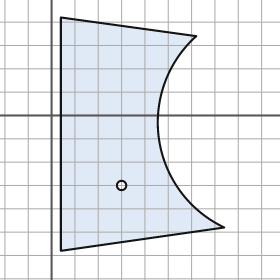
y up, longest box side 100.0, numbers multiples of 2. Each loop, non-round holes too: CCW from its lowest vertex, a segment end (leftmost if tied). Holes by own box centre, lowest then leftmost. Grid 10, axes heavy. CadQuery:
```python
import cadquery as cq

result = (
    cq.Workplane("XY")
    .moveTo(4.0, -58.0)
    .lineTo(74.0, -48.0)
    .threePointArc((46.0, -10.0), (62.0, 34.0))
    .lineTo(4.0, 42.0)
    .close()
    .moveTo(30.0, -30.0)
    .circle(2.0)
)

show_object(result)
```